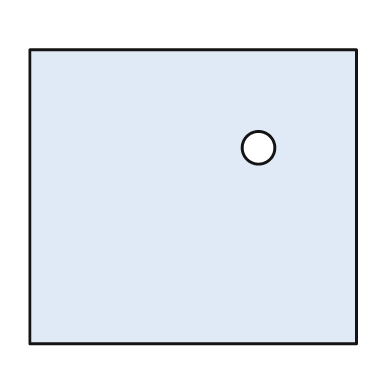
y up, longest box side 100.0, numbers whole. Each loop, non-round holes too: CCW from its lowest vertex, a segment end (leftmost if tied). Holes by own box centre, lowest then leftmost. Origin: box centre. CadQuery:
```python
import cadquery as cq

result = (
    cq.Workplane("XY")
    .moveTo(-50.0, -45.0)
    .lineTo(50.0, -45.0)
    .lineTo(50.0, 45.0)
    .lineTo(-50.0, 45.0)
    .close()
    .moveTo(20.0, 15.0)
    .circle(5.0)
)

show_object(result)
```